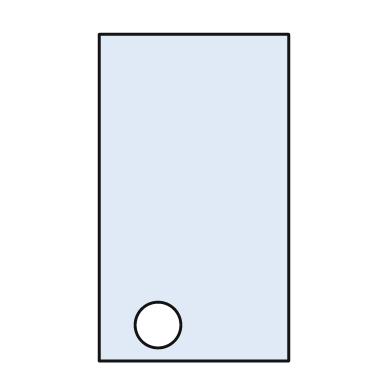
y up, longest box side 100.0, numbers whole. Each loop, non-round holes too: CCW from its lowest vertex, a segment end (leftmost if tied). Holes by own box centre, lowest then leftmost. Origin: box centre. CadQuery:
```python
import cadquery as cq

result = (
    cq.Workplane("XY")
    .moveTo(-29.0, -50.0)
    .lineTo(29.0, -50.0)
    .lineTo(29.0, 50.0)
    .lineTo(-29.0, 50.0)
    .close()
    .moveTo(-11.0, -39.0)
    .circle(7.0)
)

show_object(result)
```